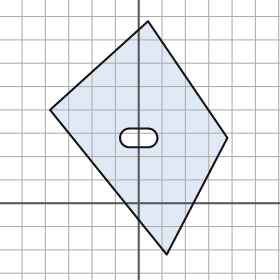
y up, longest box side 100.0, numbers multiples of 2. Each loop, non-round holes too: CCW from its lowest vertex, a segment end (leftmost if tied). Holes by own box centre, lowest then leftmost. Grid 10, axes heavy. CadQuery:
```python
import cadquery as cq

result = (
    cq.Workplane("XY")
    .moveTo(12.0, -22.0)
    .lineTo(38.0, 28.0)
    .lineTo(4.0, 78.0)
    .lineTo(-38.0, 40.0)
    .close()
    .moveTo(-4.0, 24.0)
    .lineTo(4.0, 24.0)
    .threePointArc((8.0, 28.0), (4.0, 32.0))
    .lineTo(-4.0, 32.0)
    .threePointArc((-8.0, 28.0), (-4.0, 24.0))
    .close()
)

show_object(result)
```